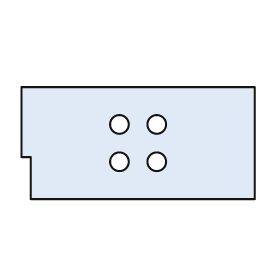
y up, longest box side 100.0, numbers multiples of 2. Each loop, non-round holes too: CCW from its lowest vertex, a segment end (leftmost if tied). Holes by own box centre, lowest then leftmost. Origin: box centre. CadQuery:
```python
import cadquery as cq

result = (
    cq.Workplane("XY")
    .moveTo(-46.0, -24.0)
    .lineTo(50.0, -24.0)
    .lineTo(50.0, 24.0)
    .lineTo(-50.0, 24.0)
    .lineTo(-50.0, -6.0)
    .lineTo(-46.0, -6.0)
    .close()
    .moveTo(-8.0, -8.0)
    .circle(4.0)
    .moveTo(8.0, -8.0)
    .circle(4.0)
    .moveTo(-8.0, 8.0)
    .circle(4.0)
    .moveTo(8.0, 8.0)
    .circle(4.0)
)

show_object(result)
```